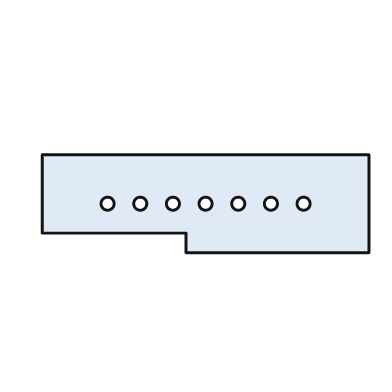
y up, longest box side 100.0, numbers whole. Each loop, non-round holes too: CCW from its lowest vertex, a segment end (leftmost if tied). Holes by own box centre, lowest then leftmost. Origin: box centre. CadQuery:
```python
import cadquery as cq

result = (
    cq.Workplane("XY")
    .moveTo(-6.0, -15.0)
    .lineTo(50.0, -15.0)
    .lineTo(50.0, 15.0)
    .lineTo(-50.0, 15.0)
    .lineTo(-50.0, -9.0)
    .lineTo(-6.0, -9.0)
    .close()
    .moveTo(-30.0, 0.0)
    .circle(2.0)
    .moveTo(-20.0, 0.0)
    .circle(2.0)
    .moveTo(-10.0, 0.0)
    .circle(2.0)
    .moveTo(0.0, 0.0)
    .circle(2.0)
    .moveTo(10.0, 0.0)
    .circle(2.0)
    .moveTo(20.0, 0.0)
    .circle(2.0)
    .moveTo(30.0, 0.0)
    .circle(2.0)
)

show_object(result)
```